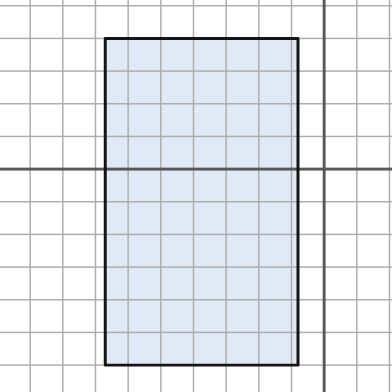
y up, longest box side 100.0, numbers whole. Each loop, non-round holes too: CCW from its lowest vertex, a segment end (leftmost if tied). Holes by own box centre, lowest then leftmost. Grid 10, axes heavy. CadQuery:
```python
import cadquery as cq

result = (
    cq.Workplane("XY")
    .moveTo(-67.0, -60.0)
    .lineTo(-8.0, -60.0)
    .lineTo(-8.0, 40.0)
    .lineTo(-67.0, 40.0)
    .close()
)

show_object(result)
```